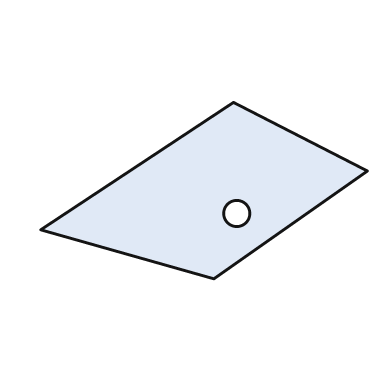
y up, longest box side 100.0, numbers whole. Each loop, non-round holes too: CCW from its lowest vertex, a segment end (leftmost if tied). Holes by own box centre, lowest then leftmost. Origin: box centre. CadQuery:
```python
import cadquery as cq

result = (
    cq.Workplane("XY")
    .moveTo(3.0, -27.0)
    .lineTo(50.0, 6.0)
    .lineTo(9.0, 27.0)
    .lineTo(-50.0, -12.0)
    .close()
    .moveTo(10.0, -7.0)
    .circle(4.0)
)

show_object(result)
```